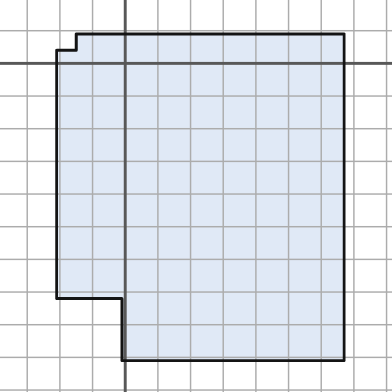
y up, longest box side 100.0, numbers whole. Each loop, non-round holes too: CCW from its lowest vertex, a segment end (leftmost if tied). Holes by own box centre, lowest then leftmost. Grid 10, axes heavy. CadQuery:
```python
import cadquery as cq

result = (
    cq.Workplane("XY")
    .moveTo(-1.0, -91.0)
    .lineTo(67.0, -91.0)
    .lineTo(67.0, 9.0)
    .lineTo(-15.0, 9.0)
    .lineTo(-15.0, 4.0)
    .lineTo(-21.0, 4.0)
    .lineTo(-21.0, -72.0)
    .lineTo(-1.0, -72.0)
    .close()
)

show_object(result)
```